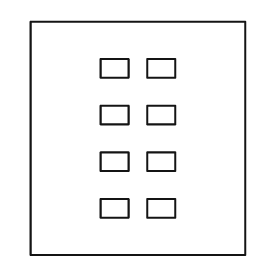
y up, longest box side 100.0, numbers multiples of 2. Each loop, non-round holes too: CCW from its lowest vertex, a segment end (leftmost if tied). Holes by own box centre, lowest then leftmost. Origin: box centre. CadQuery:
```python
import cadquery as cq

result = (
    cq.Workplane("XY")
    .moveTo(-46.0, -50.0)
    .lineTo(46.0, -50.0)
    .lineTo(46.0, 50.0)
    .lineTo(-46.0, 50.0)
    .close()
    .moveTo(-16.0, -34.0)
    .lineTo(-4.0, -34.0)
    .lineTo(-4.0, -26.0)
    .lineTo(-16.0, -26.0)
    .close()
    .moveTo(4.0, -34.0)
    .lineTo(16.0, -34.0)
    .lineTo(16.0, -26.0)
    .lineTo(4.0, -26.0)
    .close()
    .moveTo(-16.0, -14.0)
    .lineTo(-4.0, -14.0)
    .lineTo(-4.0, -6.0)
    .lineTo(-16.0, -6.0)
    .close()
    .moveTo(4.0, -14.0)
    .lineTo(16.0, -14.0)
    .lineTo(16.0, -6.0)
    .lineTo(4.0, -6.0)
    .close()
    .moveTo(-16.0, 6.0)
    .lineTo(-4.0, 6.0)
    .lineTo(-4.0, 14.0)
    .lineTo(-16.0, 14.0)
    .close()
    .moveTo(4.0, 6.0)
    .lineTo(16.0, 6.0)
    .lineTo(16.0, 14.0)
    .lineTo(4.0, 14.0)
    .close()
    .moveTo(-16.0, 26.0)
    .lineTo(-4.0, 26.0)
    .lineTo(-4.0, 34.0)
    .lineTo(-16.0, 34.0)
    .close()
    .moveTo(4.0, 26.0)
    .lineTo(16.0, 26.0)
    .lineTo(16.0, 34.0)
    .lineTo(4.0, 34.0)
    .close()
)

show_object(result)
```